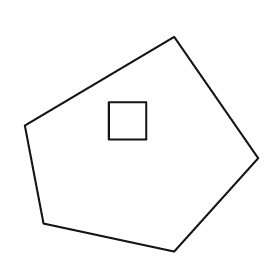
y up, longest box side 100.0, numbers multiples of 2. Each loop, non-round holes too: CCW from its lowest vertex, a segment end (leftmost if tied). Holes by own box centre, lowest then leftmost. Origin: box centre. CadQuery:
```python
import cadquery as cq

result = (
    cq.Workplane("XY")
    .moveTo(14.0, -46.0)
    .lineTo(50.0, -6.0)
    .lineTo(14.0, 46.0)
    .lineTo(-50.0, 8.0)
    .lineTo(-42.0, -34.0)
    .close()
    .moveTo(-14.0, 2.0)
    .lineTo(2.0, 2.0)
    .lineTo(2.0, 18.0)
    .lineTo(-14.0, 18.0)
    .close()
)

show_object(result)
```